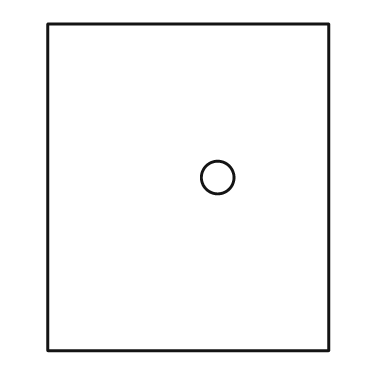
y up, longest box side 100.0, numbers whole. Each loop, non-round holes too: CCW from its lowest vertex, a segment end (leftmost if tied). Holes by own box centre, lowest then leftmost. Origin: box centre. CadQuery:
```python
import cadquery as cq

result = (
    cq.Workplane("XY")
    .moveTo(-43.0, -50.0)
    .lineTo(43.0, -50.0)
    .lineTo(43.0, 50.0)
    .lineTo(-43.0, 50.0)
    .close()
    .moveTo(9.0, 3.0)
    .circle(5.0)
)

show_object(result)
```